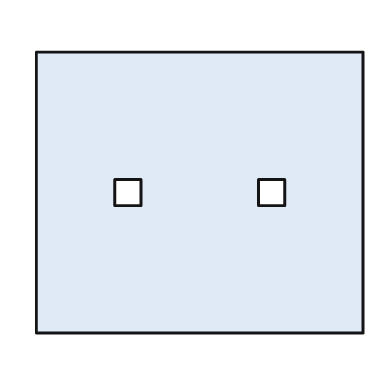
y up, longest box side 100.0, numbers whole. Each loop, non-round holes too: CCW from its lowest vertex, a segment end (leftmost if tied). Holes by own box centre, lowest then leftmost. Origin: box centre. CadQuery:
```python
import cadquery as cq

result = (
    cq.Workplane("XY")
    .moveTo(-50.0, -43.0)
    .lineTo(50.0, -43.0)
    .lineTo(50.0, 43.0)
    .lineTo(-50.0, 43.0)
    .close()
    .moveTo(-26.0, -4.0)
    .lineTo(-18.0, -4.0)
    .lineTo(-18.0, 4.0)
    .lineTo(-26.0, 4.0)
    .close()
    .moveTo(18.0, -4.0)
    .lineTo(26.0, -4.0)
    .lineTo(26.0, 4.0)
    .lineTo(18.0, 4.0)
    .close()
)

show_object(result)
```